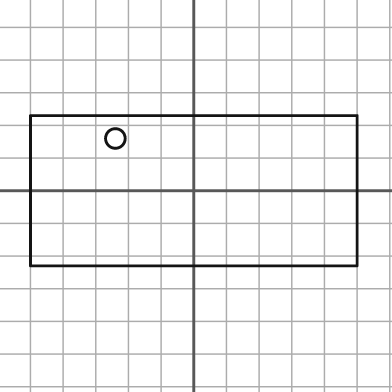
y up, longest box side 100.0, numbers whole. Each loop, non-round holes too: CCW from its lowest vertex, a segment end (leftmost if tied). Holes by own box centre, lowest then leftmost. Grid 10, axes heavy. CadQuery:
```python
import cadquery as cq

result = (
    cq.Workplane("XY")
    .moveTo(-50.0, -23.0)
    .lineTo(50.0, -23.0)
    .lineTo(50.0, 23.0)
    .lineTo(-50.0, 23.0)
    .close()
    .moveTo(-24.0, 16.0)
    .circle(3.0)
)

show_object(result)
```